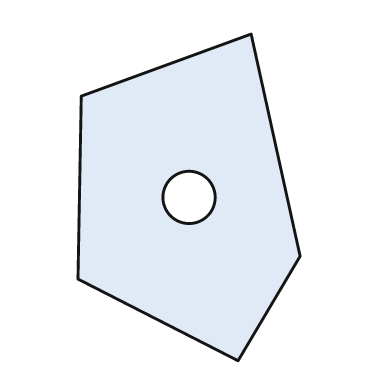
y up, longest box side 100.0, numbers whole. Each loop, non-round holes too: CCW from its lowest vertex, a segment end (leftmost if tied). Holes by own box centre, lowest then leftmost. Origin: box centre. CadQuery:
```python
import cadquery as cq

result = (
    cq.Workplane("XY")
    .moveTo(15.0, -50.0)
    .lineTo(34.0, -18.0)
    .lineTo(19.0, 50.0)
    .lineTo(-33.0, 31.0)
    .lineTo(-34.0, -25.0)
    .close()
    .moveTo(0.0, 0.0)
    .circle(8.0)
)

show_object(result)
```